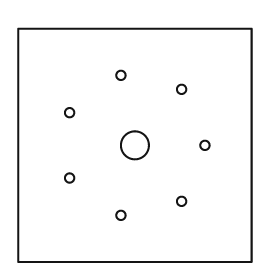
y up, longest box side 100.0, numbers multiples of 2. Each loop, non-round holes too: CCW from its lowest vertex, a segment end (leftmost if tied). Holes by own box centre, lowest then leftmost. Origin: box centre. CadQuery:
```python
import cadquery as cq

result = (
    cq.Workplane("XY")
    .moveTo(-50.0, -50.0)
    .lineTo(50.0, -50.0)
    .lineTo(50.0, 50.0)
    .lineTo(-50.0, 50.0)
    .close()
    .moveTo(-6.0, -30.0)
    .circle(2.0)
    .moveTo(20.0, -24.0)
    .circle(2.0)
    .moveTo(-28.0, -14.0)
    .circle(2.0)
    .moveTo(0.0, 0.0)
    .circle(6.0)
    .moveTo(30.0, 0.0)
    .circle(2.0)
    .moveTo(-28.0, 14.0)
    .circle(2.0)
    .moveTo(20.0, 24.0)
    .circle(2.0)
    .moveTo(-6.0, 30.0)
    .circle(2.0)
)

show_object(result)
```